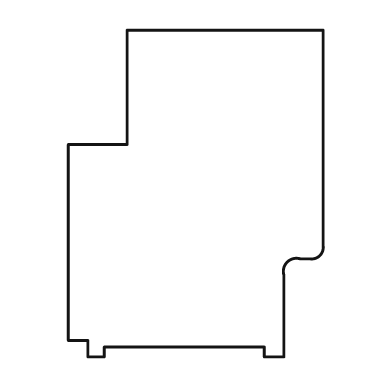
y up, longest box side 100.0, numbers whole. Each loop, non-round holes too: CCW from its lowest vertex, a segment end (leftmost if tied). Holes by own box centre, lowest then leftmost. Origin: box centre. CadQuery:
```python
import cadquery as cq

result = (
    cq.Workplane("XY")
    .moveTo(-33.0, -50.0)
    .lineTo(-28.0, -50.0)
    .lineTo(-28.0, -47.0)
    .lineTo(21.0, -47.0)
    .lineTo(21.0, -50.0)
    .lineTo(27.0, -50.0)
    .lineTo(27.0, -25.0)
    .threePointArc((28.0, -21.0), (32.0, -20.0))
    .lineTo(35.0, -20.0)
    .threePointArc((38.0, -19.0), (39.0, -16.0))
    .lineTo(39.0, 50.0)
    .lineTo(-21.0, 50.0)
    .lineTo(-21.0, 15.0)
    .lineTo(-39.0, 15.0)
    .lineTo(-39.0, -45.0)
    .lineTo(-33.0, -45.0)
    .close()
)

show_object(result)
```